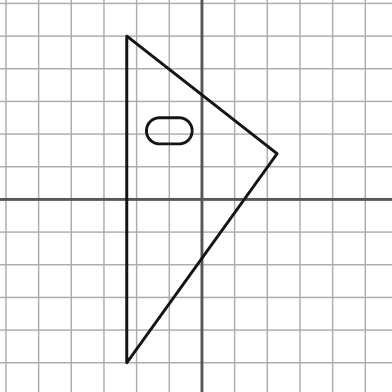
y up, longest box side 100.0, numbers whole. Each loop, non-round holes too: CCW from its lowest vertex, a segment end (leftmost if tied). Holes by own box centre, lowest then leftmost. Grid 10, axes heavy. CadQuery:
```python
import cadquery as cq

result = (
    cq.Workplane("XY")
    .moveTo(-23.0, -50.0)
    .lineTo(23.0, 14.0)
    .lineTo(-23.0, 50.0)
    .close()
    .moveTo(-13.0, 17.0)
    .lineTo(-7.0, 17.0)
    .threePointArc((-3.0, 21.0), (-7.0, 25.0))
    .lineTo(-13.0, 25.0)
    .threePointArc((-17.0, 21.0), (-13.0, 17.0))
    .close()
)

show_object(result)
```